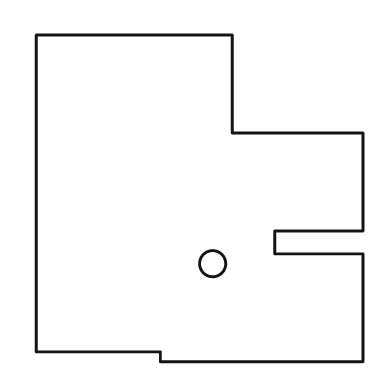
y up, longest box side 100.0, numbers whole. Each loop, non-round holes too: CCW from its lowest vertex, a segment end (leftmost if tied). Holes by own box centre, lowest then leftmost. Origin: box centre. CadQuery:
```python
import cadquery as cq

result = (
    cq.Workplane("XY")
    .moveTo(-12.0, -50.0)
    .lineTo(50.0, -50.0)
    .lineTo(50.0, -17.0)
    .lineTo(23.0, -17.0)
    .lineTo(23.0, -10.0)
    .lineTo(50.0, -10.0)
    .lineTo(50.0, 20.0)
    .lineTo(10.0, 20.0)
    .lineTo(10.0, 50.0)
    .lineTo(-50.0, 50.0)
    .lineTo(-50.0, -47.0)
    .lineTo(-12.0, -47.0)
    .close()
    .moveTo(4.0, -20.0)
    .circle(4.0)
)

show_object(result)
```